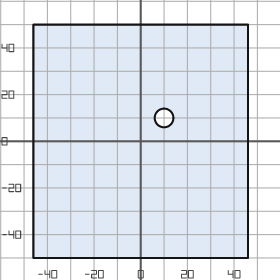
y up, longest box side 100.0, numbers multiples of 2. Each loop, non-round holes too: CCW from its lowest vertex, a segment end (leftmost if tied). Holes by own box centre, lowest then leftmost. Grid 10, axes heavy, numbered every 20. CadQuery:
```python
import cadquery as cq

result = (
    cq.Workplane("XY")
    .moveTo(-46.0, -50.0)
    .lineTo(46.0, -50.0)
    .lineTo(46.0, 50.0)
    .lineTo(-46.0, 50.0)
    .close()
    .moveTo(10.0, 10.0)
    .circle(4.0)
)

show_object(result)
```